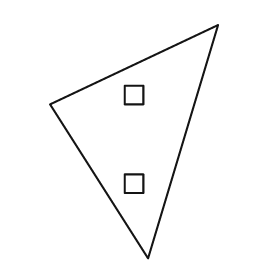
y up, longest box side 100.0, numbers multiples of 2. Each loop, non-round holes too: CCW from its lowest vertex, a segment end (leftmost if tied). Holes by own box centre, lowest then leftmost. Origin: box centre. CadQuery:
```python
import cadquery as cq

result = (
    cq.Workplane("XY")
    .moveTo(6.0, -50.0)
    .lineTo(36.0, 50.0)
    .lineTo(-36.0, 16.0)
    .close()
    .moveTo(-4.0, -22.0)
    .lineTo(4.0, -22.0)
    .lineTo(4.0, -14.0)
    .lineTo(-4.0, -14.0)
    .close()
    .moveTo(-4.0, 16.0)
    .lineTo(4.0, 16.0)
    .lineTo(4.0, 24.0)
    .lineTo(-4.0, 24.0)
    .close()
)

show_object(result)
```